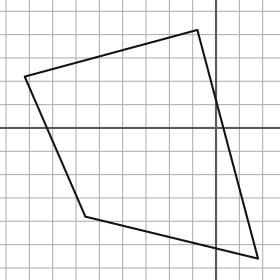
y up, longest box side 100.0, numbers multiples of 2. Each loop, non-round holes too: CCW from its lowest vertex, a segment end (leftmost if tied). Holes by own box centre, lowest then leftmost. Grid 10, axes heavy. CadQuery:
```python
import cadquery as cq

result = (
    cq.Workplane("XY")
    .moveTo(18.0, -56.0)
    .lineTo(-8.0, 42.0)
    .lineTo(-82.0, 22.0)
    .lineTo(-56.0, -38.0)
    .close()
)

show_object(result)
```